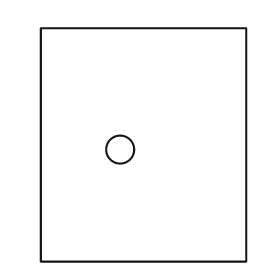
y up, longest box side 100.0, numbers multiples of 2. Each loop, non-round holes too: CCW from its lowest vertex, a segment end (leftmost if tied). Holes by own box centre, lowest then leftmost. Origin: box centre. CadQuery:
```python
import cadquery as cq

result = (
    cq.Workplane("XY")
    .moveTo(-44.0, -50.0)
    .lineTo(44.0, -50.0)
    .lineTo(44.0, 50.0)
    .lineTo(-44.0, 50.0)
    .close()
    .moveTo(-10.0, -2.0)
    .circle(6.0)
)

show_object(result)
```